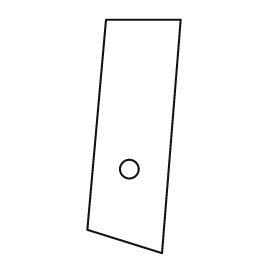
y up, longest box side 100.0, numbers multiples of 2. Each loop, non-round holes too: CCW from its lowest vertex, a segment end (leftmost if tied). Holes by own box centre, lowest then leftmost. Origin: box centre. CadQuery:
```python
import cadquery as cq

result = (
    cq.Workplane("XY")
    .moveTo(12.0, -50.0)
    .lineTo(20.0, 50.0)
    .lineTo(-12.0, 50.0)
    .lineTo(-20.0, -40.0)
    .close()
    .moveTo(-2.0, -14.0)
    .circle(4.0)
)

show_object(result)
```